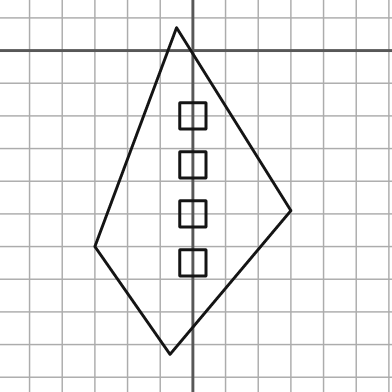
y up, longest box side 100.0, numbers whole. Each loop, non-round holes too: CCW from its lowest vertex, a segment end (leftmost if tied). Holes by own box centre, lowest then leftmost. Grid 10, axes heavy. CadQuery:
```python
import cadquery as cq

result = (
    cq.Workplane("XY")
    .moveTo(-7.0, -93.0)
    .lineTo(30.0, -49.0)
    .lineTo(-5.0, 7.0)
    .lineTo(-30.0, -60.0)
    .close()
    .moveTo(-4.0, -69.0)
    .lineTo(4.0, -69.0)
    .lineTo(4.0, -61.0)
    .lineTo(-4.0, -61.0)
    .close()
    .moveTo(-4.0, -54.0)
    .lineTo(4.0, -54.0)
    .lineTo(4.0, -46.0)
    .lineTo(-4.0, -46.0)
    .close()
    .moveTo(-4.0, -39.0)
    .lineTo(4.0, -39.0)
    .lineTo(4.0, -31.0)
    .lineTo(-4.0, -31.0)
    .close()
    .moveTo(-4.0, -24.0)
    .lineTo(4.0, -24.0)
    .lineTo(4.0, -16.0)
    .lineTo(-4.0, -16.0)
    .close()
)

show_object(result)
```